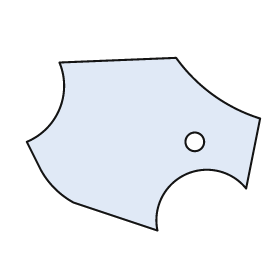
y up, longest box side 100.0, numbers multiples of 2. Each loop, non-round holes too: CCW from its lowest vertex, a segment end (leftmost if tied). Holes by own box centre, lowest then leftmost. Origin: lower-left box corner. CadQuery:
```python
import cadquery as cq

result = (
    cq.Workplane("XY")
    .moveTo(56.0, 0.0)
    .threePointArc((68.0, 24.0), (94.0, 18.0))
    .lineTo(100.0, 48.0)
    .threePointArc((80.0, 58.0), (64.0, 74.0))
    .lineTo(14.0, 72.0)
    .threePointArc((14.0, 52.0), (0.0, 38.0))
    .lineTo(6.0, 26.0)
    .threePointArc((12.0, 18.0), (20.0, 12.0))
    .close()
    .moveTo(72.0, 38.0)
    .circle(4.0)
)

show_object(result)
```